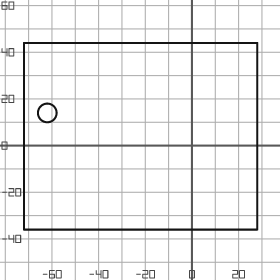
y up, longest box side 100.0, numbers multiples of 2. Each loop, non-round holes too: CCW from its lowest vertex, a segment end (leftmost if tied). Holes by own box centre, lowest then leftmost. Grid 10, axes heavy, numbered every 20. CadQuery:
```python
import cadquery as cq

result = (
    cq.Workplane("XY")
    .moveTo(-72.0, -36.0)
    .lineTo(28.0, -36.0)
    .lineTo(28.0, 44.0)
    .lineTo(-72.0, 44.0)
    .close()
    .moveTo(-62.0, 14.0)
    .circle(4.0)
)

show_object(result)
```